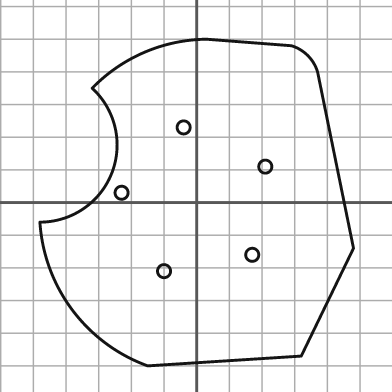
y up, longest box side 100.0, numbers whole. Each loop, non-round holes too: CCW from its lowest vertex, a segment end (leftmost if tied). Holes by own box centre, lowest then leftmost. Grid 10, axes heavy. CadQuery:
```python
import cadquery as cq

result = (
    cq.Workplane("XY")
    .moveTo(-15.0, -50.0)
    .lineTo(32.0, -47.0)
    .lineTo(48.0, -14.0)
    .lineTo(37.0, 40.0)
    .threePointArc((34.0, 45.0), (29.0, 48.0))
    .lineTo(3.0, 50.0)
    .threePointArc((-16.0, 46.0), (-32.0, 35.0))
    .threePointArc((-26.0, 9.0), (-48.0, -6.0))
    .threePointArc((-38.0, -33.0), (-15.0, -50.0))
    .close()
    .moveTo(-10.0, -21.0)
    .circle(2.0)
    .moveTo(17.0, -16.0)
    .circle(2.0)
    .moveTo(-23.0, 3.0)
    .circle(2.0)
    .moveTo(21.0, 11.0)
    .circle(2.0)
    .moveTo(-4.0, 23.0)
    .circle(2.0)
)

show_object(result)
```